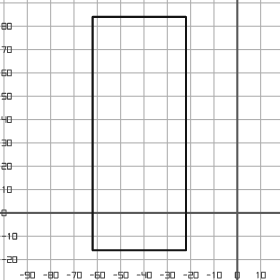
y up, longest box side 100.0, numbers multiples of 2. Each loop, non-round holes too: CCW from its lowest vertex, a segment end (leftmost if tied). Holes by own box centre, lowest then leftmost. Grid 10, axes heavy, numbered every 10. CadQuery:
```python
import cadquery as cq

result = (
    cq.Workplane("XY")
    .moveTo(-62.0, -16.0)
    .lineTo(-22.0, -16.0)
    .lineTo(-22.0, 84.0)
    .lineTo(-62.0, 84.0)
    .close()
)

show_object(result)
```